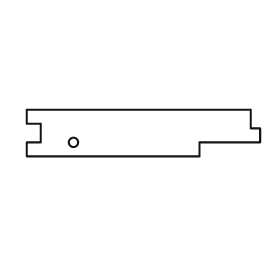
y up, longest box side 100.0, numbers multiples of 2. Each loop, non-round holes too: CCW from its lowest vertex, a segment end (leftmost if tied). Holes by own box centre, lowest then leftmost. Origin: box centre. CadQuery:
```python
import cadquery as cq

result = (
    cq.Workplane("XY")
    .moveTo(-50.0, -10.0)
    .lineTo(24.0, -10.0)
    .lineTo(24.0, -4.0)
    .lineTo(50.0, -4.0)
    .lineTo(50.0, 2.0)
    .lineTo(46.0, 2.0)
    .lineTo(46.0, 10.0)
    .lineTo(-50.0, 10.0)
    .lineTo(-50.0, 4.0)
    .lineTo(-44.0, 4.0)
    .lineTo(-44.0, -4.0)
    .lineTo(-50.0, -4.0)
    .close()
    .moveTo(-30.0, -4.0)
    .circle(2.0)
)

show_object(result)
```